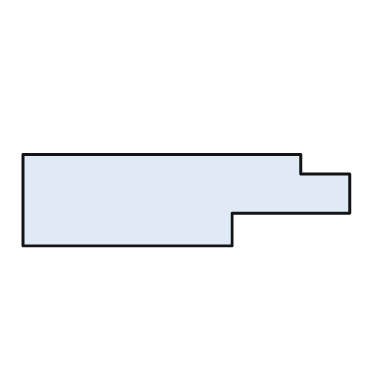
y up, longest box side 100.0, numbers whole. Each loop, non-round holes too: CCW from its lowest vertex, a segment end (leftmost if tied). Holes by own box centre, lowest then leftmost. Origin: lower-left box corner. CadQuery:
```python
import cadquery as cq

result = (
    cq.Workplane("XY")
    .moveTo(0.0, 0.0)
    .lineTo(64.0, 0.0)
    .lineTo(64.0, 10.0)
    .lineTo(100.0, 10.0)
    .lineTo(100.0, 22.0)
    .lineTo(85.0, 22.0)
    .lineTo(85.0, 28.0)
    .lineTo(0.0, 28.0)
    .close()
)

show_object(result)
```